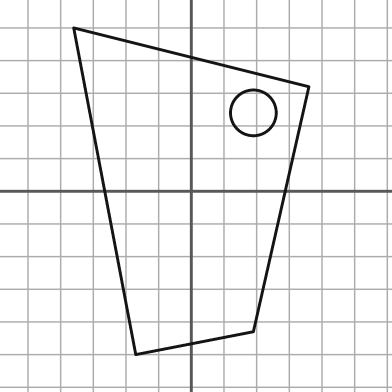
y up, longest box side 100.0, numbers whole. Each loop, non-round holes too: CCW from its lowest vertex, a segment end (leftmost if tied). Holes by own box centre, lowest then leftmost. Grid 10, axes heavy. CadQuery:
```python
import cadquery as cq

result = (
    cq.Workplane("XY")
    .moveTo(-17.0, -50.0)
    .lineTo(19.0, -43.0)
    .lineTo(36.0, 32.0)
    .lineTo(-36.0, 50.0)
    .close()
    .moveTo(19.0, 24.0)
    .circle(7.0)
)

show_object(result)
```